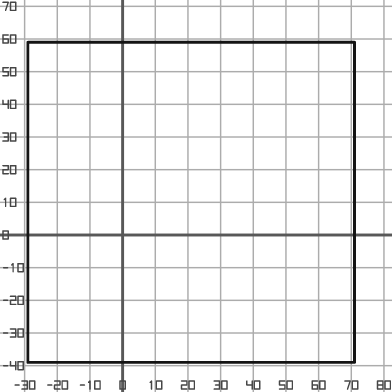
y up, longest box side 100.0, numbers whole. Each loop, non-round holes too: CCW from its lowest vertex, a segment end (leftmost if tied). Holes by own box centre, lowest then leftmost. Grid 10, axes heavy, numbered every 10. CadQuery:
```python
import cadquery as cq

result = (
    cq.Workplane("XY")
    .moveTo(-29.0, -39.0)
    .lineTo(71.0, -39.0)
    .lineTo(71.0, 59.0)
    .lineTo(-29.0, 59.0)
    .close()
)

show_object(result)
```